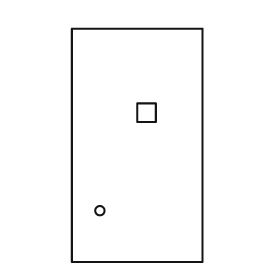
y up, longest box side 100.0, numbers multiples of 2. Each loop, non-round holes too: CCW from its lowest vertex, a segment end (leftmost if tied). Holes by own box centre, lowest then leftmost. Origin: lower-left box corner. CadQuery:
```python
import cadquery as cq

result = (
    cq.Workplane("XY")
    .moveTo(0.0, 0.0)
    .lineTo(56.0, 0.0)
    .lineTo(56.0, 100.0)
    .lineTo(0.0, 100.0)
    .close()
    .moveTo(12.0, 22.0)
    .circle(2.0)
    .moveTo(28.0, 60.0)
    .lineTo(36.0, 60.0)
    .lineTo(36.0, 68.0)
    .lineTo(28.0, 68.0)
    .close()
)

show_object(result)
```